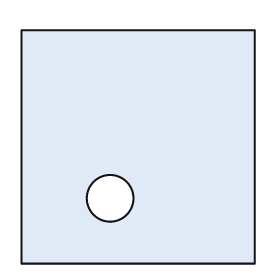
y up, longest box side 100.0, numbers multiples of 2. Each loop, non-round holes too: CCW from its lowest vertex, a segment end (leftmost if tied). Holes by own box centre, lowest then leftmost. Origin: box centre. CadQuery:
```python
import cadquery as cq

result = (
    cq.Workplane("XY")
    .moveTo(-50.0, -50.0)
    .lineTo(50.0, -50.0)
    .lineTo(50.0, 50.0)
    .lineTo(-50.0, 50.0)
    .close()
    .moveTo(-12.0, -22.0)
    .circle(10.0)
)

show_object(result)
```